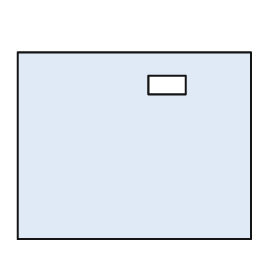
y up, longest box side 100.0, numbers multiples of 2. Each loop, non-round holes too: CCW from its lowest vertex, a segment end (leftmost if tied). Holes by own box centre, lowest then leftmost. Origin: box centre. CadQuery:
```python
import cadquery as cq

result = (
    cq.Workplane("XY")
    .moveTo(-50.0, -40.0)
    .lineTo(50.0, -40.0)
    .lineTo(50.0, 40.0)
    .lineTo(-50.0, 40.0)
    .close()
    .moveTo(6.0, 22.0)
    .lineTo(22.0, 22.0)
    .lineTo(22.0, 30.0)
    .lineTo(6.0, 30.0)
    .close()
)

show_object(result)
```